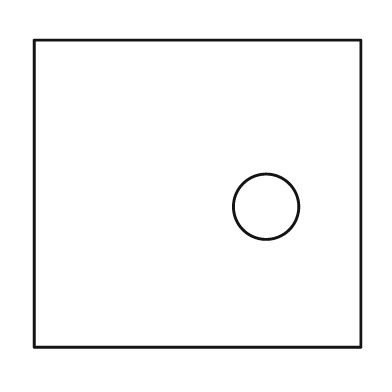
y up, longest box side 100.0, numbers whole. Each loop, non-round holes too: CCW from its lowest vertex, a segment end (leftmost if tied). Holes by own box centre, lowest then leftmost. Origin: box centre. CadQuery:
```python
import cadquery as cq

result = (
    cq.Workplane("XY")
    .moveTo(-50.0, -47.0)
    .lineTo(50.0, -47.0)
    .lineTo(50.0, 47.0)
    .lineTo(-50.0, 47.0)
    .close()
    .moveTo(21.0, -4.0)
    .circle(10.0)
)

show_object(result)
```